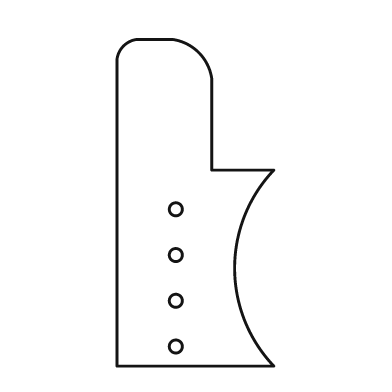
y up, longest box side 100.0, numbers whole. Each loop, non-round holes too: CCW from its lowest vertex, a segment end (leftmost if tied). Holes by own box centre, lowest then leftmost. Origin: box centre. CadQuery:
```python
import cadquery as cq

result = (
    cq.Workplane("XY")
    .moveTo(-24.0, -50.0)
    .lineTo(24.0, -50.0)
    .threePointArc((12.0, -20.0), (24.0, 10.0))
    .lineTo(5.0, 10.0)
    .lineTo(5.0, 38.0)
    .threePointArc((1.0, 46.0), (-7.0, 50.0))
    .lineTo(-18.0, 50.0)
    .threePointArc((-22.0, 48.0), (-24.0, 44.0))
    .close()
    .moveTo(-6.0, -44.0)
    .circle(2.0)
    .moveTo(-6.0, -30.0)
    .circle(2.0)
    .moveTo(-6.0, -16.0)
    .circle(2.0)
    .moveTo(-6.0, -2.0)
    .circle(2.0)
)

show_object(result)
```